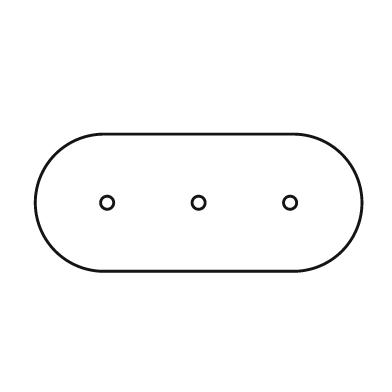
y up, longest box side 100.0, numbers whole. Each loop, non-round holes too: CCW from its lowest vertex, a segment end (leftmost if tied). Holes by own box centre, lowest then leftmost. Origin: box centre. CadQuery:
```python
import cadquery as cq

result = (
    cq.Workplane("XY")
    .moveTo(-29.0, -21.0)
    .lineTo(29.0, -21.0)
    .threePointArc((50.0, 0.0), (29.0, 21.0))
    .lineTo(-29.0, 21.0)
    .threePointArc((-50.0, 0.0), (-29.0, -21.0))
    .close()
    .moveTo(-28.0, 0.0)
    .circle(2.0)
    .moveTo(0.0, 0.0)
    .circle(2.0)
    .moveTo(28.0, 0.0)
    .circle(2.0)
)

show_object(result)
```